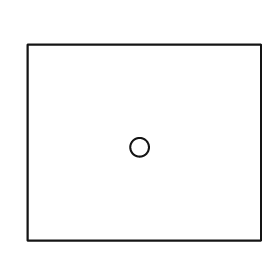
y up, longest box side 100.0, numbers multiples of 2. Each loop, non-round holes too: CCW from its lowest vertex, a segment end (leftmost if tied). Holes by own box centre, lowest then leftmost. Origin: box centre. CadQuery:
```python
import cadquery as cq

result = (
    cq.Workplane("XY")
    .moveTo(-50.0, -42.0)
    .lineTo(50.0, -42.0)
    .lineTo(50.0, 42.0)
    .lineTo(-50.0, 42.0)
    .close()
    .moveTo(-2.0, -2.0)
    .circle(4.0)
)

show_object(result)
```